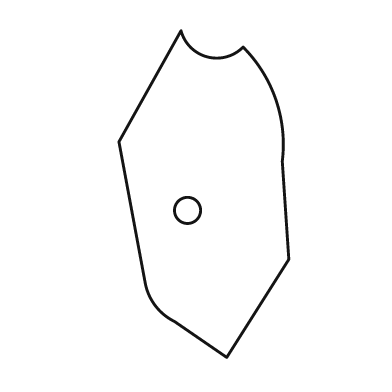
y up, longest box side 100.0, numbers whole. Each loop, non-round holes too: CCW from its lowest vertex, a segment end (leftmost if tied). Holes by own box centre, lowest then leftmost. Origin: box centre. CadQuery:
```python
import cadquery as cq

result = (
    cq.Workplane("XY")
    .moveTo(7.0, -50.0)
    .lineTo(26.0, -20.0)
    .lineTo(24.0, 10.0)
    .threePointArc((22.0, 29.0), (12.0, 45.0))
    .threePointArc((1.0, 42.0), (-7.0, 50.0))
    .lineTo(-26.0, 16.0)
    .lineTo(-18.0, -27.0)
    .threePointArc((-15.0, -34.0), (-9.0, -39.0))
    .close()
    .moveTo(-5.0, -5.0)
    .circle(4.0)
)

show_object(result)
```